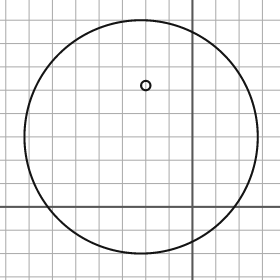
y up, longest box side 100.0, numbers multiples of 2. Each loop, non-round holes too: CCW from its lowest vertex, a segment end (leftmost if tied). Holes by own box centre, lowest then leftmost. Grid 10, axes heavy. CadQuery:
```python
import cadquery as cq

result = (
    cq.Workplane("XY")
    .moveTo(-22.0, 30.0)
    .circle(50.0)
    .moveTo(-20.0, 52.0)
    .circle(2.0)
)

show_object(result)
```